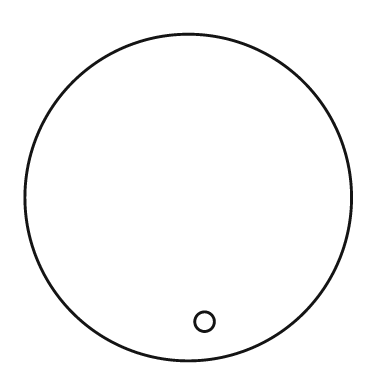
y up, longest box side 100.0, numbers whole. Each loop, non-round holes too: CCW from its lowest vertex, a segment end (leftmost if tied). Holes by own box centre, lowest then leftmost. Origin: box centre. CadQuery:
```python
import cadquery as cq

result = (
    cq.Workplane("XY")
    .moveTo(0.0, 0.0)
    .circle(50.0)
    .moveTo(5.0, -38.0)
    .circle(3.0)
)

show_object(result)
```